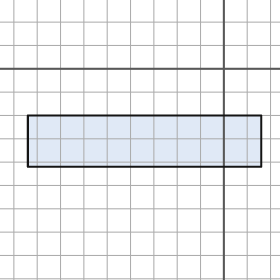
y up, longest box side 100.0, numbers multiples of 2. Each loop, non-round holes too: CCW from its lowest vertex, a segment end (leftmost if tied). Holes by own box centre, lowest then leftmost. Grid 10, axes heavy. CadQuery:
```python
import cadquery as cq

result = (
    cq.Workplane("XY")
    .moveTo(-84.0, -42.0)
    .lineTo(16.0, -42.0)
    .lineTo(16.0, -20.0)
    .lineTo(-84.0, -20.0)
    .close()
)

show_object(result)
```